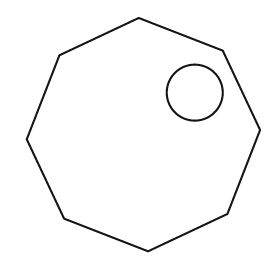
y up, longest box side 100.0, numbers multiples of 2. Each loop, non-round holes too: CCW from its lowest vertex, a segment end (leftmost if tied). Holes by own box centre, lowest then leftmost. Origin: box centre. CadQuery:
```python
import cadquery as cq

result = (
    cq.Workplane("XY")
    .moveTo(2.0, -50.0)
    .lineTo(36.0, -34.0)
    .lineTo(50.0, 2.0)
    .lineTo(34.0, 36.0)
    .lineTo(-2.0, 50.0)
    .lineTo(-36.0, 34.0)
    .lineTo(-50.0, -2.0)
    .lineTo(-34.0, -36.0)
    .close()
    .moveTo(22.0, 18.0)
    .circle(12.0)
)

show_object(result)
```